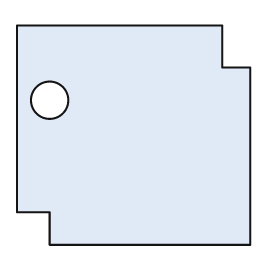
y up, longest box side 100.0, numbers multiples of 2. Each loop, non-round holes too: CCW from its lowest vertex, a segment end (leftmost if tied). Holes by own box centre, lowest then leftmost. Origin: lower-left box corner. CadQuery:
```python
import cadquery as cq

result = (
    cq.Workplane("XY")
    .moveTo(14.0, 0.0)
    .lineTo(100.0, 0.0)
    .lineTo(100.0, 76.0)
    .lineTo(88.0, 76.0)
    .lineTo(88.0, 94.0)
    .lineTo(0.0, 94.0)
    .lineTo(0.0, 14.0)
    .lineTo(14.0, 14.0)
    .close()
    .moveTo(14.0, 62.0)
    .circle(8.0)
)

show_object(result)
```